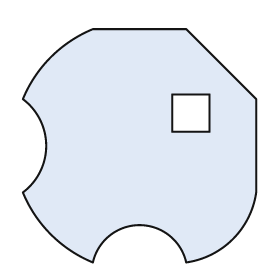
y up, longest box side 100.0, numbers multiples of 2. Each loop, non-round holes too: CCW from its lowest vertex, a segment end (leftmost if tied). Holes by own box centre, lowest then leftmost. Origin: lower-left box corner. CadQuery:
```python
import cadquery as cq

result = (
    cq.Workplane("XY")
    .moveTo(30.0, 0.0)
    .threePointArc((50.0, 16.0), (70.0, 0.0))
    .threePointArc((90.0, 10.0), (100.0, 30.0))
    .lineTo(100.0, 70.0)
    .lineTo(70.0, 100.0)
    .lineTo(30.0, 100.0)
    .threePointArc((12.0, 88.0), (0.0, 70.0))
    .threePointArc((10.0, 50.0), (0.0, 30.0))
    .threePointArc((12.0, 12.0), (30.0, 0.0))
    .close()
    .moveTo(64.0, 56.0)
    .lineTo(80.0, 56.0)
    .lineTo(80.0, 72.0)
    .lineTo(64.0, 72.0)
    .close()
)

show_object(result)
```